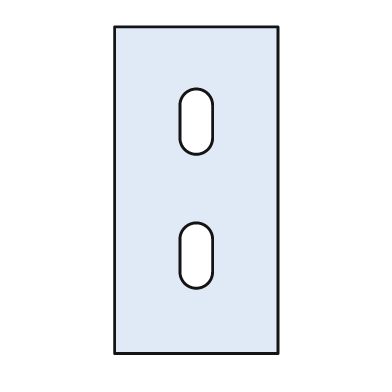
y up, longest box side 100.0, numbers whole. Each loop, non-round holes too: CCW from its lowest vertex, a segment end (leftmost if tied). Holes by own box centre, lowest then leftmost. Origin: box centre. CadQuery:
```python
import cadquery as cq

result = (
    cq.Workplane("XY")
    .moveTo(-25.0, -50.0)
    .lineTo(25.0, -50.0)
    .lineTo(25.0, 50.0)
    .lineTo(-25.0, 50.0)
    .close()
    .moveTo(-5.0, -25.0)
    .threePointArc((0.0, -30.0), (5.0, -25.0))
    .lineTo(5.0, -15.0)
    .threePointArc((0.0, -10.0), (-5.0, -15.0))
    .close()
    .moveTo(-5.0, 16.0)
    .threePointArc((0.0, 11.0), (5.0, 16.0))
    .lineTo(5.0, 26.0)
    .threePointArc((0.0, 31.0), (-5.0, 26.0))
    .close()
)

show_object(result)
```